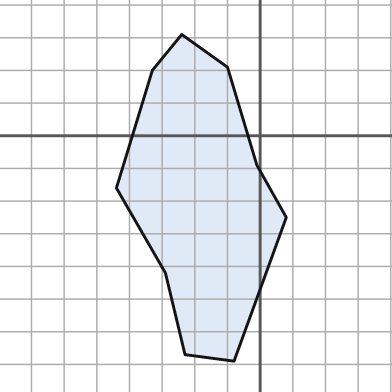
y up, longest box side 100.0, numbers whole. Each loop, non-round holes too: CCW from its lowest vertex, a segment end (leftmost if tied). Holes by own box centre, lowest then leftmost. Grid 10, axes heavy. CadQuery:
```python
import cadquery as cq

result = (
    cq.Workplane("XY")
    .moveTo(-8.0, -69.0)
    .lineTo(8.0, -25.0)
    .lineTo(-1.0, -9.0)
    .lineTo(-10.0, 21.0)
    .lineTo(-24.0, 31.0)
    .lineTo(-33.0, 20.0)
    .lineTo(-44.0, -16.0)
    .lineTo(-29.0, -42.0)
    .lineTo(-23.0, -67.0)
    .close()
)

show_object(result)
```